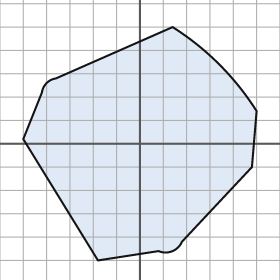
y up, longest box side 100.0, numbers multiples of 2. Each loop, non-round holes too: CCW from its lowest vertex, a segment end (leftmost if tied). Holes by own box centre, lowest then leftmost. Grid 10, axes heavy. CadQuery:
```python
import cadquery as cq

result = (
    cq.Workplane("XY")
    .moveTo(-18.0, -50.0)
    .lineTo(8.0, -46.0)
    .threePointArc((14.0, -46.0), (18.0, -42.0))
    .lineTo(48.0, -10.0)
    .lineTo(50.0, 14.0)
    .threePointArc((34.0, 34.0), (14.0, 50.0))
    .lineTo(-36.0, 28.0)
    .threePointArc((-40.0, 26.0), (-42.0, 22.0))
    .lineTo(-50.0, 2.0)
    .close()
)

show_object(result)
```